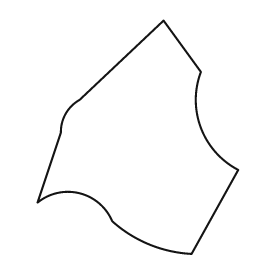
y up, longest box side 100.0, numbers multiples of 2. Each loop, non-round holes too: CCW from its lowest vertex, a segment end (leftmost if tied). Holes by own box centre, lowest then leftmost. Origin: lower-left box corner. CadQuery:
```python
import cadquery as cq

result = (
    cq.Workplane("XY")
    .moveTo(66.0, 0.0)
    .lineTo(86.0, 36.0)
    .threePointArc((70.0, 54.0), (70.0, 78.0))
    .lineTo(54.0, 100.0)
    .lineTo(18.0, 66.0)
    .threePointArc((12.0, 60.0), (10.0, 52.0))
    .lineTo(0.0, 22.0)
    .threePointArc((18.0, 26.0), (32.0, 14.0))
    .threePointArc((48.0, 4.0), (66.0, 0.0))
    .close()
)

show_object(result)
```